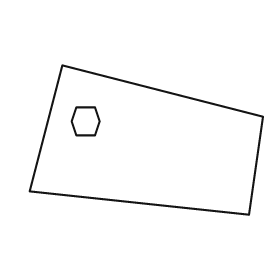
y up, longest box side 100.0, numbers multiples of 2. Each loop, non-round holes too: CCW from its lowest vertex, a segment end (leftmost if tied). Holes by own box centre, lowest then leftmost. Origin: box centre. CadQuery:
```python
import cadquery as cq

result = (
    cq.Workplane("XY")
    .moveTo(44.0, -32.0)
    .lineTo(50.0, 10.0)
    .lineTo(-36.0, 32.0)
    .lineTo(-50.0, -22.0)
    .close()
    .moveTo(-30.0, 2.0)
    .lineTo(-22.0, 2.0)
    .lineTo(-20.0, 8.0)
    .lineTo(-22.0, 14.0)
    .lineTo(-30.0, 14.0)
    .lineTo(-32.0, 8.0)
    .close()
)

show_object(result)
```